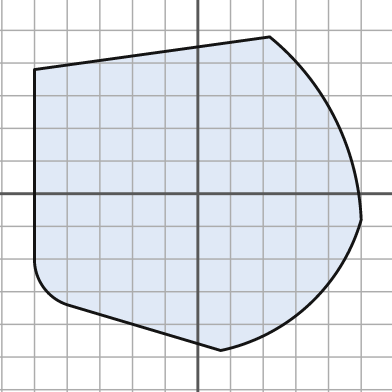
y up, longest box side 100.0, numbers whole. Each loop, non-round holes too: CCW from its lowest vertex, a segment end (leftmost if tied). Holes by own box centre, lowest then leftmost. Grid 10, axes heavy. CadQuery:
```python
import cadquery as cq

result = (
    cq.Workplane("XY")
    .moveTo(7.0, -48.0)
    .threePointArc((34.0, -34.0), (50.0, -8.0))
    .threePointArc((42.0, 23.0), (22.0, 48.0))
    .lineTo(-50.0, 38.0)
    .lineTo(-50.0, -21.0)
    .threePointArc((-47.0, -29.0), (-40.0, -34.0))
    .close()
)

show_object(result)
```